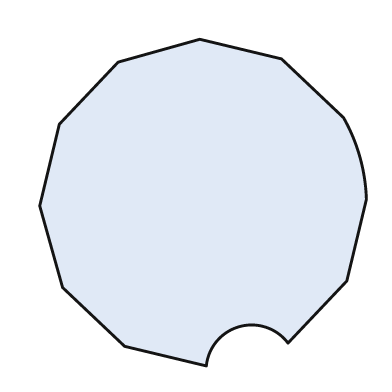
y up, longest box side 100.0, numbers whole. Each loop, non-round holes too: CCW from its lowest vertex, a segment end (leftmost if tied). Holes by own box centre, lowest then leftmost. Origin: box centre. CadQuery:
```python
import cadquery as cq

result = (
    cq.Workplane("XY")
    .moveTo(1.0, -50.0)
    .threePointArc((11.0, -38.0), (26.0, -43.0))
    .lineTo(44.0, -24.0)
    .lineTo(50.0, 1.0)
    .threePointArc((48.0, 14.0), (43.0, 26.0))
    .lineTo(24.0, 44.0)
    .lineTo(-1.0, 50.0)
    .lineTo(-26.0, 43.0)
    .lineTo(-44.0, 24.0)
    .lineTo(-50.0, -1.0)
    .lineTo(-43.0, -26.0)
    .lineTo(-24.0, -44.0)
    .close()
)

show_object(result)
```